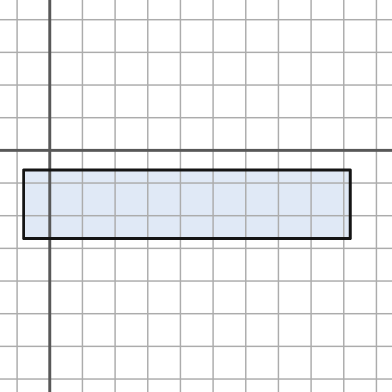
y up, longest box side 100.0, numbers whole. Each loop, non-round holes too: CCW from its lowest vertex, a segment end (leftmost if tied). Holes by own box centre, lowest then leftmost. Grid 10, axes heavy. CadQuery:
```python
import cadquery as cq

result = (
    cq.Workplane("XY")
    .moveTo(-8.0, -27.0)
    .lineTo(92.0, -27.0)
    .lineTo(92.0, -6.0)
    .lineTo(-8.0, -6.0)
    .close()
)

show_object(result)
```